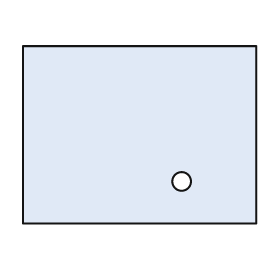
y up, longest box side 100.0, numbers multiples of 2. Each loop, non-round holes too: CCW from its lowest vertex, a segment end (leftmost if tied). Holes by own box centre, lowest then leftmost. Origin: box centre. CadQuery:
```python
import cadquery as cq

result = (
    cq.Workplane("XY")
    .moveTo(-50.0, -38.0)
    .lineTo(50.0, -38.0)
    .lineTo(50.0, 38.0)
    .lineTo(-50.0, 38.0)
    .close()
    .moveTo(18.0, -20.0)
    .circle(4.0)
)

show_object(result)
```